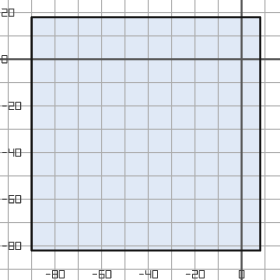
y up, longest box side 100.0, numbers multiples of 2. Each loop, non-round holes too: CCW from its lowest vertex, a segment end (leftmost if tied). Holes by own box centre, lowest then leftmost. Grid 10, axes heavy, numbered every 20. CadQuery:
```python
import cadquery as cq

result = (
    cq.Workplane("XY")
    .moveTo(-90.0, -82.0)
    .lineTo(8.0, -82.0)
    .lineTo(8.0, 18.0)
    .lineTo(-90.0, 18.0)
    .close()
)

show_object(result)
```